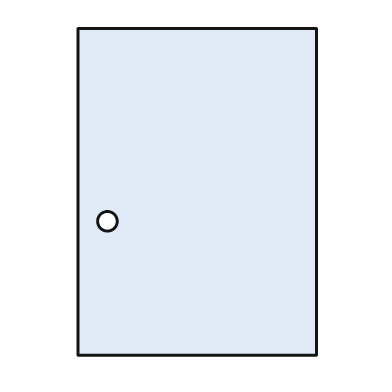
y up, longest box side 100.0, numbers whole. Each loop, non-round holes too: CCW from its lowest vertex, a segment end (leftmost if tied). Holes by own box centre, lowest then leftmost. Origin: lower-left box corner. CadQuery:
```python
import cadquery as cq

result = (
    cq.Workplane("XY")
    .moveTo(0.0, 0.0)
    .lineTo(73.0, 0.0)
    .lineTo(73.0, 100.0)
    .lineTo(0.0, 100.0)
    .close()
    .moveTo(9.0, 41.0)
    .circle(3.0)
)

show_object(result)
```